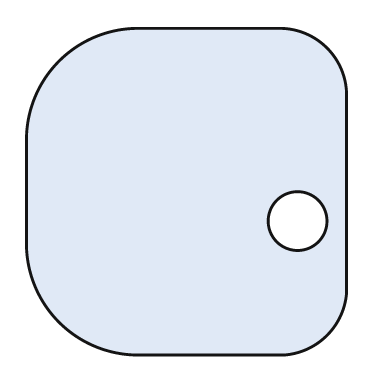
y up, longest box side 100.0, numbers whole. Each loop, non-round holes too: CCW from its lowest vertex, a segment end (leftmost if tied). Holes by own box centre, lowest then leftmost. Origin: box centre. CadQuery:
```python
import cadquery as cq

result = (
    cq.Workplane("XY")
    .moveTo(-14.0, -50.0)
    .lineTo(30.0, -50.0)
    .threePointArc((43.0, -44.0), (49.0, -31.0))
    .lineTo(49.0, 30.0)
    .threePointArc((43.0, 44.0), (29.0, 50.0))
    .lineTo(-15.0, 50.0)
    .threePointArc((-39.0, 40.0), (-49.0, 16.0))
    .lineTo(-49.0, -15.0)
    .threePointArc((-39.0, -40.0), (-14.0, -50.0))
    .close()
    .moveTo(34.0, -9.0)
    .circle(9.0)
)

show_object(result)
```